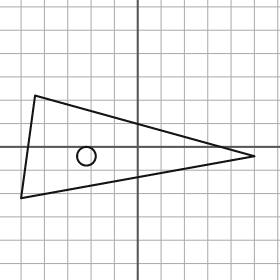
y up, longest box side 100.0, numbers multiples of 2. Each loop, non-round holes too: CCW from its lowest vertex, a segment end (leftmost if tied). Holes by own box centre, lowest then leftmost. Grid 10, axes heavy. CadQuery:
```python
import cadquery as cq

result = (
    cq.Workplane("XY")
    .moveTo(-50.0, -22.0)
    .lineTo(50.0, -4.0)
    .lineTo(-44.0, 22.0)
    .close()
    .moveTo(-22.0, -4.0)
    .circle(4.0)
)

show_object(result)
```